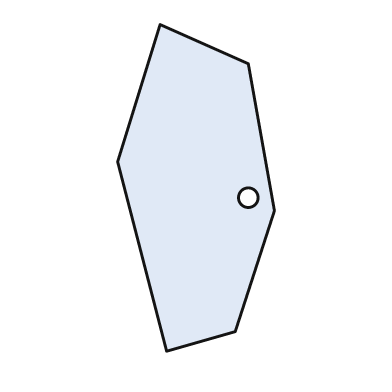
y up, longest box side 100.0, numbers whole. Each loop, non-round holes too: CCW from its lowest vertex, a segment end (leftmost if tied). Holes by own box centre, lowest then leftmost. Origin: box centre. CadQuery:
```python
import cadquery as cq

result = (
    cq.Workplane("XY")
    .moveTo(-9.0, -50.0)
    .lineTo(12.0, -44.0)
    .lineTo(24.0, -7.0)
    .lineTo(16.0, 38.0)
    .lineTo(-11.0, 50.0)
    .lineTo(-24.0, 8.0)
    .close()
    .moveTo(16.0, -3.0)
    .circle(3.0)
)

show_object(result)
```